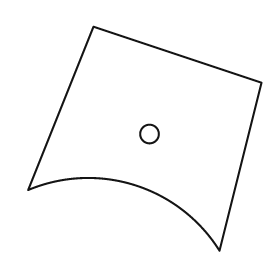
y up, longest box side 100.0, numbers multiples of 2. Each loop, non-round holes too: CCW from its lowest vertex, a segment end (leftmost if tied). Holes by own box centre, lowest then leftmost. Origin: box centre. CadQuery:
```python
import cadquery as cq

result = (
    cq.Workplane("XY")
    .moveTo(32.0, -48.0)
    .lineTo(50.0, 24.0)
    .lineTo(-22.0, 48.0)
    .lineTo(-50.0, -22.0)
    .threePointArc((-4.0, -20.0), (32.0, -48.0))
    .close()
    .moveTo(2.0, 2.0)
    .circle(4.0)
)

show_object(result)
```